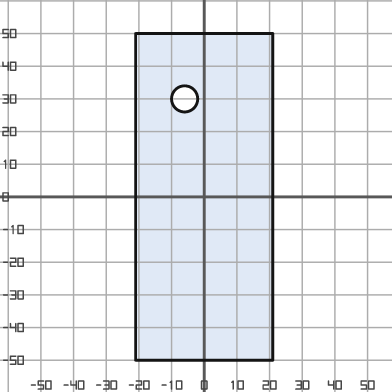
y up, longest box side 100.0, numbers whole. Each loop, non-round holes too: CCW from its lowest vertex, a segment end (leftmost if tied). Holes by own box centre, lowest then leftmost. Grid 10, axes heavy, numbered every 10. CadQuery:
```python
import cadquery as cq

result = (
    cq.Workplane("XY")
    .moveTo(-21.0, -50.0)
    .lineTo(21.0, -50.0)
    .lineTo(21.0, 50.0)
    .lineTo(-21.0, 50.0)
    .close()
    .moveTo(-6.0, 30.0)
    .circle(4.0)
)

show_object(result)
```